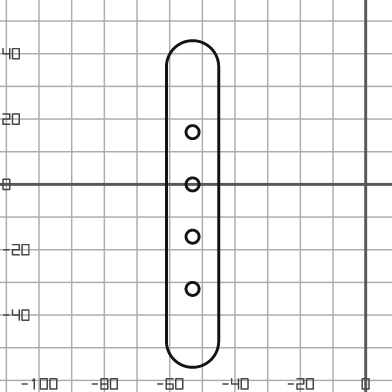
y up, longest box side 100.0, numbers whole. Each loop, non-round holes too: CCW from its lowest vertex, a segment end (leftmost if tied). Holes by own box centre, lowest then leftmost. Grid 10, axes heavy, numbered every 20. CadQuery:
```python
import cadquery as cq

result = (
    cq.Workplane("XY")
    .moveTo(-61.0, -48.0)
    .threePointArc((-53.0, -56.0), (-45.0, -48.0))
    .lineTo(-45.0, 36.0)
    .threePointArc((-53.0, 44.0), (-61.0, 36.0))
    .close()
    .moveTo(-53.0, -32.0)
    .circle(2.0)
    .moveTo(-53.0, -16.0)
    .circle(2.0)
    .moveTo(-53.0, 0.0)
    .circle(2.0)
    .moveTo(-53.0, 16.0)
    .circle(2.0)
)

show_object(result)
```